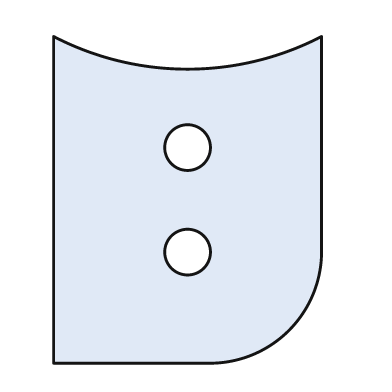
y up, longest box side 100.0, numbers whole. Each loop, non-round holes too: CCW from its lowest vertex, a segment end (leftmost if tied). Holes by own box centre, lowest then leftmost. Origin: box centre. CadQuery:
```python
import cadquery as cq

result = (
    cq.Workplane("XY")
    .moveTo(-41.0, -50.0)
    .lineTo(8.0, -50.0)
    .threePointArc((31.0, -40.0), (41.0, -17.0))
    .lineTo(41.0, 50.0)
    .threePointArc((0.0, 40.0), (-41.0, 50.0))
    .close()
    .moveTo(0.0, -16.0)
    .circle(7.0)
    .moveTo(0.0, 16.0)
    .circle(7.0)
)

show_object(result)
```